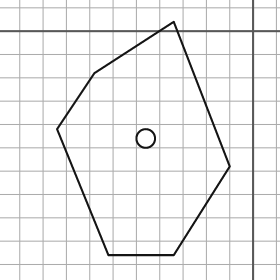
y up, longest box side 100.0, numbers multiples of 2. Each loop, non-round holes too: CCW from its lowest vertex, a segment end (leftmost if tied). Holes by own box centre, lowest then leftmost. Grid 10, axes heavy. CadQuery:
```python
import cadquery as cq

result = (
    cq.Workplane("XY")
    .moveTo(-62.0, -96.0)
    .lineTo(-34.0, -96.0)
    .lineTo(-10.0, -58.0)
    .lineTo(-34.0, 4.0)
    .lineTo(-68.0, -18.0)
    .lineTo(-84.0, -42.0)
    .close()
    .moveTo(-46.0, -46.0)
    .circle(4.0)
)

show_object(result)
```